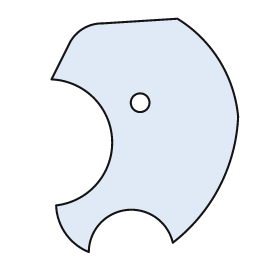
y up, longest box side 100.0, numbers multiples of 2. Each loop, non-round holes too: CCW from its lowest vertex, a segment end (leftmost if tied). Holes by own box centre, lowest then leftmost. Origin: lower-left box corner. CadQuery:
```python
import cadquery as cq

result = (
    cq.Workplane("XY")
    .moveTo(16.0, 0.0)
    .threePointArc((32.0, 18.0), (52.0, 4.0))
    .threePointArc((72.0, 28.0), (80.0, 58.0))
    .threePointArc((72.0, 82.0), (54.0, 100.0))
    .lineTo(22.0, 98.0)
    .threePointArc((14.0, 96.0), (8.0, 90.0))
    .lineTo(0.0, 74.0)
    .threePointArc((26.0, 48.0), (2.0, 20.0))
    .threePointArc((6.0, 8.0), (16.0, 0.0))
    .close()
    .moveTo(38.0, 64.0)
    .circle(4.0)
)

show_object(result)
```